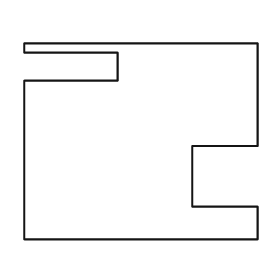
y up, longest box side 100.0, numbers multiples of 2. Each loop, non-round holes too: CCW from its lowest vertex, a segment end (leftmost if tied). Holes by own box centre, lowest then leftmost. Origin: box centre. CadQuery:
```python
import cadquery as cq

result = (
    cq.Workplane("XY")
    .moveTo(-50.0, -42.0)
    .lineTo(50.0, -42.0)
    .lineTo(50.0, -28.0)
    .lineTo(22.0, -28.0)
    .lineTo(22.0, -2.0)
    .lineTo(50.0, -2.0)
    .lineTo(50.0, 42.0)
    .lineTo(-50.0, 42.0)
    .lineTo(-50.0, 38.0)
    .lineTo(-10.0, 38.0)
    .lineTo(-10.0, 26.0)
    .lineTo(-50.0, 26.0)
    .close()
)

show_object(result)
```